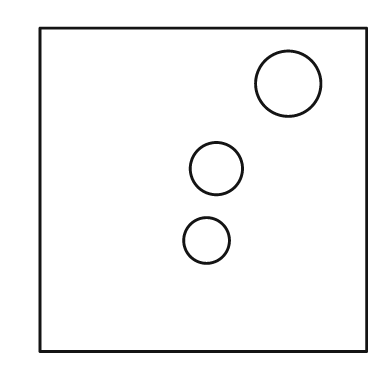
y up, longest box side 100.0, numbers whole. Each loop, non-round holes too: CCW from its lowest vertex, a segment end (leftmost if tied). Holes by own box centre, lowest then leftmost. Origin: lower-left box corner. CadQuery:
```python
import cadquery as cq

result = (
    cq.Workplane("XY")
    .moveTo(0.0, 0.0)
    .lineTo(100.0, 0.0)
    .lineTo(100.0, 99.0)
    .lineTo(0.0, 99.0)
    .close()
    .moveTo(51.0, 34.0)
    .circle(7.0)
    .moveTo(54.0, 56.0)
    .circle(8.0)
    .moveTo(76.0, 82.0)
    .circle(10.0)
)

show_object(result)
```